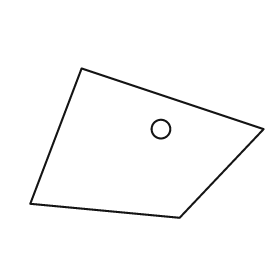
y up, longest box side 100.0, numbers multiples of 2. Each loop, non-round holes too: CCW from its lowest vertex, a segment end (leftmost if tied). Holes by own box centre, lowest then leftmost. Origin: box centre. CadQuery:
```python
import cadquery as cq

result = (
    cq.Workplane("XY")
    .moveTo(14.0, -32.0)
    .lineTo(50.0, 6.0)
    .lineTo(-28.0, 32.0)
    .lineTo(-50.0, -26.0)
    .close()
    .moveTo(6.0, 6.0)
    .circle(4.0)
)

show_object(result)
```